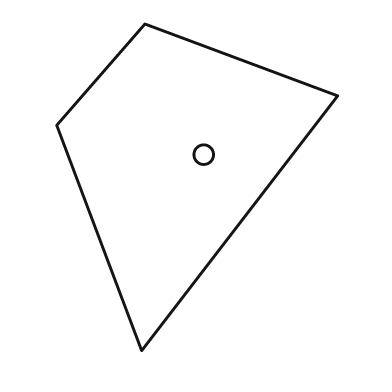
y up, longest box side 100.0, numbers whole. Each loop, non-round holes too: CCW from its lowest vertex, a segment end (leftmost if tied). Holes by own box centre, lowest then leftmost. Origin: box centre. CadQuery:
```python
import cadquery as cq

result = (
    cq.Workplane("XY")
    .moveTo(-17.0, -50.0)
    .lineTo(43.0, 28.0)
    .lineTo(-16.0, 50.0)
    .lineTo(-43.0, 19.0)
    .close()
    .moveTo(2.0, 10.0)
    .circle(3.0)
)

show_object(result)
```